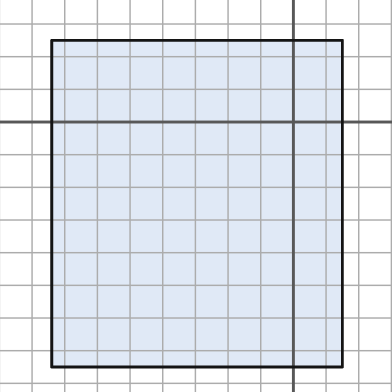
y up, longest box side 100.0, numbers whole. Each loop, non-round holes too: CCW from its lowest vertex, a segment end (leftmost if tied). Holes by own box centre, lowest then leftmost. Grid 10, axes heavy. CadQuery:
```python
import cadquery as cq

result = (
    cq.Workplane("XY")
    .moveTo(-74.0, -75.0)
    .lineTo(15.0, -75.0)
    .lineTo(15.0, 25.0)
    .lineTo(-74.0, 25.0)
    .close()
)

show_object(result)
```